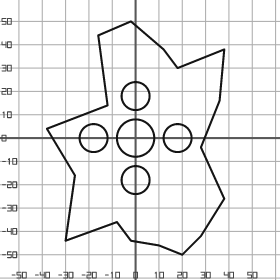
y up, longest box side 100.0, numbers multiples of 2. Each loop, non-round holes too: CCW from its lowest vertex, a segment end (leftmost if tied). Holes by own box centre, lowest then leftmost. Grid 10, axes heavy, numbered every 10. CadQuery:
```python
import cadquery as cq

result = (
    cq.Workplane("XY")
    .moveTo(20.0, -50.0)
    .lineTo(28.0, -42.0)
    .lineTo(38.0, -26.0)
    .lineTo(28.0, -4.0)
    .lineTo(36.0, 16.0)
    .lineTo(38.0, 38.0)
    .lineTo(18.0, 30.0)
    .lineTo(12.0, 38.0)
    .lineTo(-2.0, 50.0)
    .lineTo(-16.0, 44.0)
    .lineTo(-12.0, 14.0)
    .lineTo(-38.0, 4.0)
    .lineTo(-26.0, -16.0)
    .lineTo(-30.0, -44.0)
    .lineTo(-8.0, -36.0)
    .lineTo(-2.0, -44.0)
    .lineTo(10.0, -46.0)
    .close()
    .moveTo(0.0, -18.0)
    .circle(6.0)
    .moveTo(-18.0, 0.0)
    .circle(6.0)
    .moveTo(0.0, 0.0)
    .circle(8.0)
    .moveTo(18.0, 0.0)
    .circle(6.0)
    .moveTo(0.0, 18.0)
    .circle(6.0)
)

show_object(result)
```